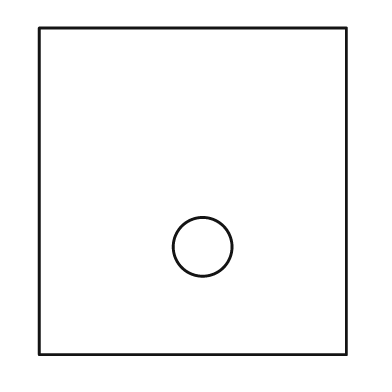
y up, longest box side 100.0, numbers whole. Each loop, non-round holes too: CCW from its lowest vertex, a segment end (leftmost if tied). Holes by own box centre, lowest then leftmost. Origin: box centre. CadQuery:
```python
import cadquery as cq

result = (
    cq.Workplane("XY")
    .moveTo(-47.0, -50.0)
    .lineTo(47.0, -50.0)
    .lineTo(47.0, 50.0)
    .lineTo(-47.0, 50.0)
    .close()
    .moveTo(3.0, -17.0)
    .circle(9.0)
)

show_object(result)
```